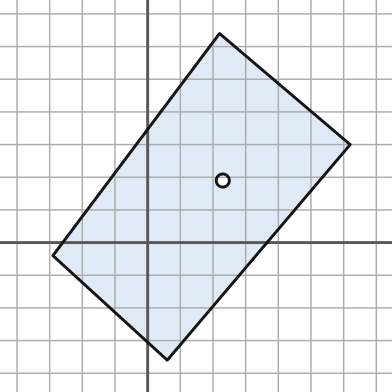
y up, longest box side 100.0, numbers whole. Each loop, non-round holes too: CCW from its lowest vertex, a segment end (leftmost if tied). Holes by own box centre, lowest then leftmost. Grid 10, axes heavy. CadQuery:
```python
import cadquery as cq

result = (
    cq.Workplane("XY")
    .moveTo(6.0, -36.0)
    .lineTo(62.0, 30.0)
    .lineTo(22.0, 64.0)
    .lineTo(-29.0, -4.0)
    .close()
    .moveTo(23.0, 19.0)
    .circle(2.0)
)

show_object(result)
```